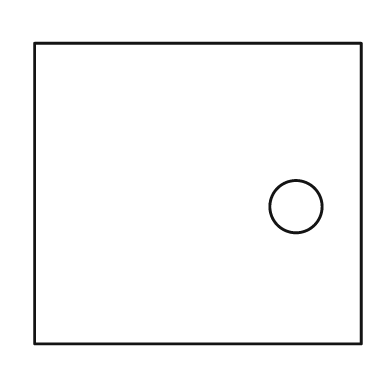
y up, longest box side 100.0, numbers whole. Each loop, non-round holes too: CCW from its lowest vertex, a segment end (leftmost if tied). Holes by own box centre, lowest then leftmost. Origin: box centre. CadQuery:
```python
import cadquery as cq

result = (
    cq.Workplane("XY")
    .moveTo(-50.0, -46.0)
    .lineTo(50.0, -46.0)
    .lineTo(50.0, 46.0)
    .lineTo(-50.0, 46.0)
    .close()
    .moveTo(30.0, -4.0)
    .circle(8.0)
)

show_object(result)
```